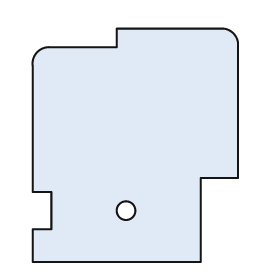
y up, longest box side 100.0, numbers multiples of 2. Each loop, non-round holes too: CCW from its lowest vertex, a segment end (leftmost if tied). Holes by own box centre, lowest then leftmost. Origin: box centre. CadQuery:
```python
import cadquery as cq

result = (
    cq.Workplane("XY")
    .moveTo(-44.0, -50.0)
    .lineTo(28.0, -50.0)
    .lineTo(28.0, -14.0)
    .lineTo(44.0, -14.0)
    .lineTo(44.0, 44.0)
    .threePointArc((42.0, 48.0), (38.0, 50.0))
    .lineTo(-8.0, 50.0)
    .lineTo(-8.0, 42.0)
    .lineTo(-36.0, 42.0)
    .threePointArc((-42.0, 40.0), (-44.0, 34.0))
    .lineTo(-44.0, -20.0)
    .lineTo(-36.0, -20.0)
    .lineTo(-36.0, -36.0)
    .lineTo(-44.0, -36.0)
    .close()
    .moveTo(-4.0, -28.0)
    .circle(4.0)
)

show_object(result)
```